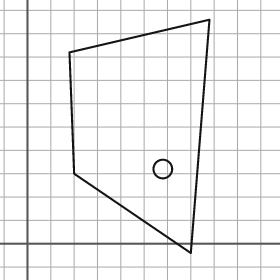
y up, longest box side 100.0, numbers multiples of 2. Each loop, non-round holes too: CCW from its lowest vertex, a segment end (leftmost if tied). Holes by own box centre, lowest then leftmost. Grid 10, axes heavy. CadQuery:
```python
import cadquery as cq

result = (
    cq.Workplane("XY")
    .moveTo(70.0, -4.0)
    .lineTo(78.0, 96.0)
    .lineTo(18.0, 82.0)
    .lineTo(20.0, 30.0)
    .close()
    .moveTo(58.0, 32.0)
    .circle(4.0)
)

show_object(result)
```